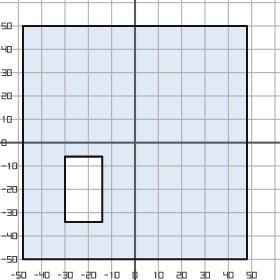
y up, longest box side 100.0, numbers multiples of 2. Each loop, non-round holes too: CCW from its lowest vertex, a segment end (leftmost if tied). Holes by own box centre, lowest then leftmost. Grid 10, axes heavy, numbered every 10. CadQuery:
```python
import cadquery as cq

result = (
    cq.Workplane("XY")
    .moveTo(-48.0, -50.0)
    .lineTo(48.0, -50.0)
    .lineTo(48.0, 50.0)
    .lineTo(-48.0, 50.0)
    .close()
    .moveTo(-30.0, -34.0)
    .lineTo(-14.0, -34.0)
    .lineTo(-14.0, -6.0)
    .lineTo(-30.0, -6.0)
    .close()
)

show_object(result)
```